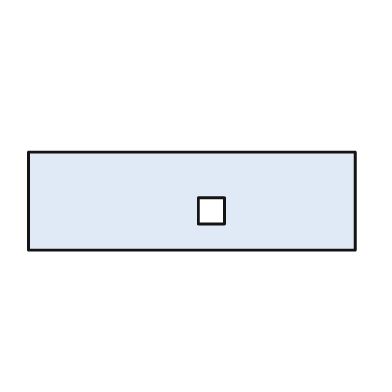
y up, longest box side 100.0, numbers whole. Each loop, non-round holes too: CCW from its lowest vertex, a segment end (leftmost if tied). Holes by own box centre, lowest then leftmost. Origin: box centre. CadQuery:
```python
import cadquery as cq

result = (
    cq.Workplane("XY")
    .moveTo(-50.0, -15.0)
    .lineTo(50.0, -15.0)
    .lineTo(50.0, 15.0)
    .lineTo(-50.0, 15.0)
    .close()
    .moveTo(2.0, -7.0)
    .lineTo(10.0, -7.0)
    .lineTo(10.0, 1.0)
    .lineTo(2.0, 1.0)
    .close()
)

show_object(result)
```